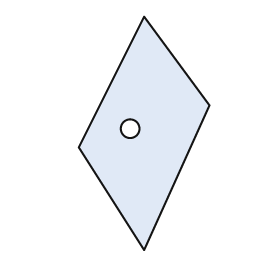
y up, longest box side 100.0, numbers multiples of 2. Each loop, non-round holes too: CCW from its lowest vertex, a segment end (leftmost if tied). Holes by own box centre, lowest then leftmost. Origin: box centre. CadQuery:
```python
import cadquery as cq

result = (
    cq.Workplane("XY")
    .moveTo(0.0, -50.0)
    .lineTo(28.0, 12.0)
    .lineTo(0.0, 50.0)
    .lineTo(-28.0, -6.0)
    .close()
    .moveTo(-6.0, 2.0)
    .circle(4.0)
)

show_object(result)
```